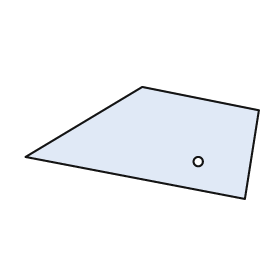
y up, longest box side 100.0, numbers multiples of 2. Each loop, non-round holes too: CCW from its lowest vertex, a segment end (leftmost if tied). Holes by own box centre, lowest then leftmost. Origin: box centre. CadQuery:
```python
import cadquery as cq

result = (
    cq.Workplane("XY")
    .moveTo(44.0, -24.0)
    .lineTo(50.0, 14.0)
    .lineTo(0.0, 24.0)
    .lineTo(-50.0, -6.0)
    .close()
    .moveTo(24.0, -8.0)
    .circle(2.0)
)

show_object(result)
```